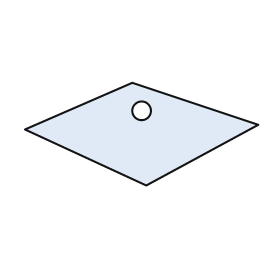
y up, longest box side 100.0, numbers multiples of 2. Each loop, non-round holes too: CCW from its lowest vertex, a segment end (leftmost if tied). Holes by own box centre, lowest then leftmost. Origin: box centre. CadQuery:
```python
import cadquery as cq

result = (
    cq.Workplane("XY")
    .moveTo(2.0, -22.0)
    .lineTo(50.0, 4.0)
    .lineTo(-4.0, 22.0)
    .lineTo(-50.0, 2.0)
    .close()
    .moveTo(0.0, 10.0)
    .circle(4.0)
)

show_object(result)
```